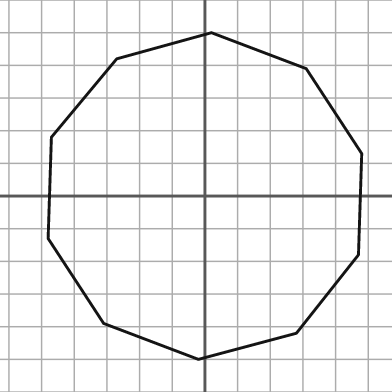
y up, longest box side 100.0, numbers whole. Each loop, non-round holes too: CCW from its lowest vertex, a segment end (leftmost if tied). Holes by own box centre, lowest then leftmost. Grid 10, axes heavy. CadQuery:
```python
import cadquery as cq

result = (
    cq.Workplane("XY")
    .moveTo(-2.0, -50.0)
    .lineTo(28.0, -42.0)
    .lineTo(47.0, -18.0)
    .lineTo(48.0, 13.0)
    .lineTo(31.0, 39.0)
    .lineTo(2.0, 50.0)
    .lineTo(-27.0, 42.0)
    .lineTo(-47.0, 18.0)
    .lineTo(-48.0, -13.0)
    .lineTo(-31.0, -39.0)
    .close()
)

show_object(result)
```